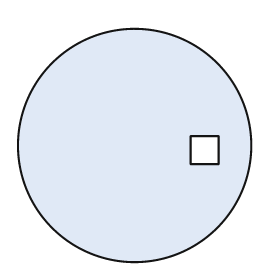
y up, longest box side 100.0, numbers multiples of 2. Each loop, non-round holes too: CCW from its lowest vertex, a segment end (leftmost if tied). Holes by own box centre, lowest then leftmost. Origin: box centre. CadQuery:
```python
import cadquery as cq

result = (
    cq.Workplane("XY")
    .moveTo(0.0, 0.0)
    .circle(50.0)
    .moveTo(24.0, -8.0)
    .lineTo(36.0, -8.0)
    .lineTo(36.0, 4.0)
    .lineTo(24.0, 4.0)
    .close()
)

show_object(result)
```